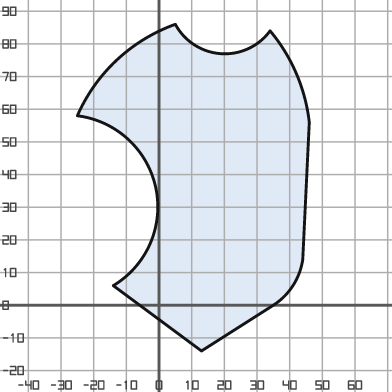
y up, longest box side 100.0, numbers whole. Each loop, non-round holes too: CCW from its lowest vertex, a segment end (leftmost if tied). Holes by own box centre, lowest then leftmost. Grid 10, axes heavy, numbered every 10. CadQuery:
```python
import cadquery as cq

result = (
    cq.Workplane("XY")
    .moveTo(13.0, -14.0)
    .lineTo(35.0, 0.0)
    .threePointArc((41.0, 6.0), (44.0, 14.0))
    .lineTo(46.0, 56.0)
    .threePointArc((42.0, 71.0), (34.0, 84.0))
    .threePointArc((19.0, 77.0), (5.0, 86.0))
    .threePointArc((-13.0, 75.0), (-25.0, 58.0))
    .threePointArc((-1.0, 36.0), (-14.0, 6.0))
    .close()
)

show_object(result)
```